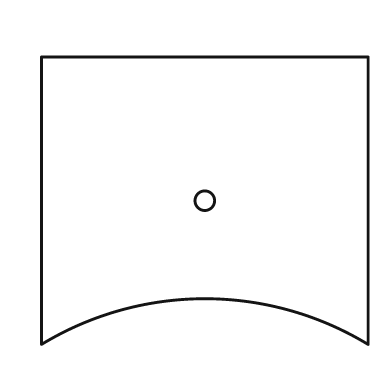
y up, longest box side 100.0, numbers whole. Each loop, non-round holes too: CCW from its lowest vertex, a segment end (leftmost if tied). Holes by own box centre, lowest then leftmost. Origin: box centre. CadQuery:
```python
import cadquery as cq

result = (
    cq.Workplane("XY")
    .moveTo(-50.0, -44.0)
    .threePointArc((0.0, -30.0), (50.0, -44.0))
    .lineTo(50.0, 44.0)
    .lineTo(-50.0, 44.0)
    .close()
    .moveTo(0.0, 0.0)
    .circle(3.0)
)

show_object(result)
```